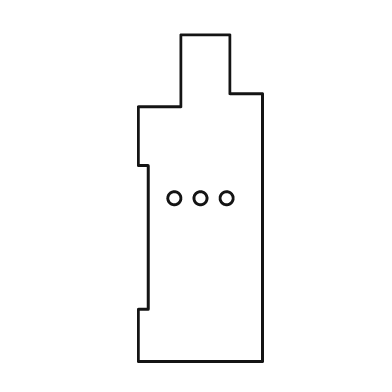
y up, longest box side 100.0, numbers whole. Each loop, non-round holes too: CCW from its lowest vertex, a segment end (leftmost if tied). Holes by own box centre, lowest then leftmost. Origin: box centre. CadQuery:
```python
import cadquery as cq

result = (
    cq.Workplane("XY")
    .moveTo(-19.0, -50.0)
    .lineTo(19.0, -50.0)
    .lineTo(19.0, 32.0)
    .lineTo(9.0, 32.0)
    .lineTo(9.0, 50.0)
    .lineTo(-6.0, 50.0)
    .lineTo(-6.0, 28.0)
    .lineTo(-19.0, 28.0)
    .lineTo(-19.0, 10.0)
    .lineTo(-16.0, 10.0)
    .lineTo(-16.0, -34.0)
    .lineTo(-19.0, -34.0)
    .close()
    .moveTo(-8.0, 0.0)
    .circle(2.0)
    .moveTo(0.0, 0.0)
    .circle(2.0)
    .moveTo(8.0, 0.0)
    .circle(2.0)
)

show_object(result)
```